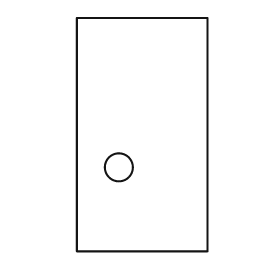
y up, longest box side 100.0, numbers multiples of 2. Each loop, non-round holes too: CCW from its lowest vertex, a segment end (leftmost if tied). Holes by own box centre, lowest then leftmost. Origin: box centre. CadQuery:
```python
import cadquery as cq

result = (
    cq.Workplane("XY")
    .moveTo(-28.0, -50.0)
    .lineTo(28.0, -50.0)
    .lineTo(28.0, 50.0)
    .lineTo(-28.0, 50.0)
    .close()
    .moveTo(-10.0, -14.0)
    .circle(6.0)
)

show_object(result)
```